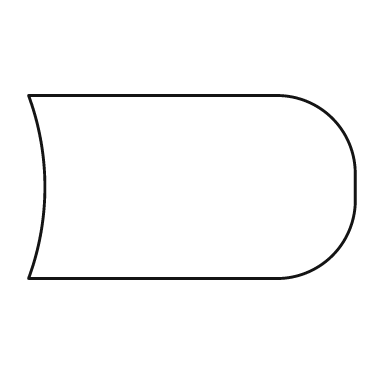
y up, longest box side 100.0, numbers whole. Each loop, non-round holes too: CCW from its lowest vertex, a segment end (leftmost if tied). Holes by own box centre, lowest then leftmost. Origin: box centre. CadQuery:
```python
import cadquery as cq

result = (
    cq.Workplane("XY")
    .moveTo(-50.0, -28.0)
    .lineTo(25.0, -28.0)
    .threePointArc((43.0, -21.0), (50.0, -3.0))
    .lineTo(50.0, 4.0)
    .threePointArc((43.0, 21.0), (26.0, 28.0))
    .lineTo(-50.0, 28.0)
    .threePointArc((-45.0, 0.0), (-50.0, -28.0))
    .close()
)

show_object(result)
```